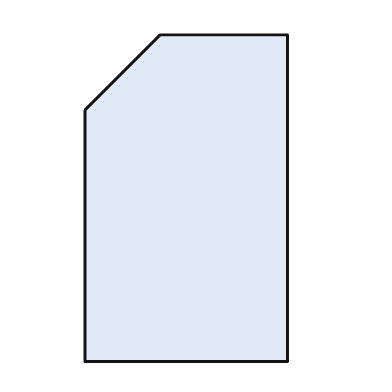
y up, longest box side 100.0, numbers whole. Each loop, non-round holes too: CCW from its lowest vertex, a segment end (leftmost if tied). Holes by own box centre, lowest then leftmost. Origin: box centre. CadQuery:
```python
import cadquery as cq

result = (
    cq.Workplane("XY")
    .moveTo(-31.0, -50.0)
    .lineTo(31.0, -50.0)
    .lineTo(31.0, 50.0)
    .lineTo(-8.0, 50.0)
    .lineTo(-31.0, 27.0)
    .close()
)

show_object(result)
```